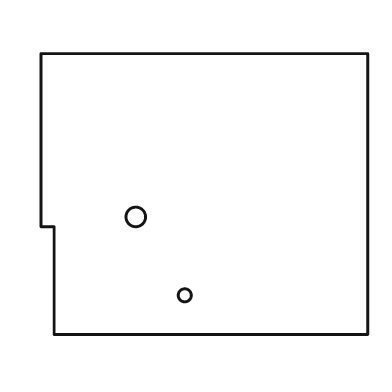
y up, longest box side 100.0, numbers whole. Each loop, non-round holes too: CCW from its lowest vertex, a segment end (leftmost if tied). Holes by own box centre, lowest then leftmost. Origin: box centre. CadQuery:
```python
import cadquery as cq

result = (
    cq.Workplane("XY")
    .moveTo(-46.0, -43.0)
    .lineTo(50.0, -43.0)
    .lineTo(50.0, 43.0)
    .lineTo(-50.0, 43.0)
    .lineTo(-50.0, -10.0)
    .lineTo(-46.0, -10.0)
    .close()
    .moveTo(-6.0, -31.0)
    .circle(2.0)
    .moveTo(-21.0, -7.0)
    .circle(3.0)
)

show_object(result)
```